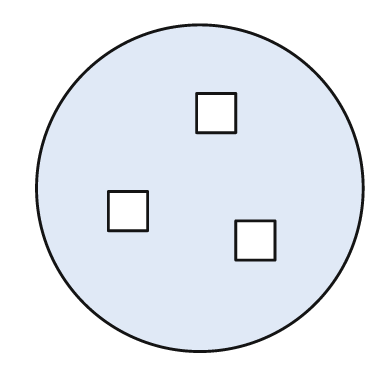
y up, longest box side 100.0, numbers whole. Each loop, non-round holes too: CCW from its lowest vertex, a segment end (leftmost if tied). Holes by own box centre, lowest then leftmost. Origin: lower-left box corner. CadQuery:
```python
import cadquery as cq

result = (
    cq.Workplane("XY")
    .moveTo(50.0, 50.0)
    .circle(50.0)
    .moveTo(61.0, 28.0)
    .lineTo(73.0, 28.0)
    .lineTo(73.0, 40.0)
    .lineTo(61.0, 40.0)
    .close()
    .moveTo(22.0, 37.0)
    .lineTo(34.0, 37.0)
    .lineTo(34.0, 49.0)
    .lineTo(22.0, 49.0)
    .close()
    .moveTo(49.0, 67.0)
    .lineTo(61.0, 67.0)
    .lineTo(61.0, 79.0)
    .lineTo(49.0, 79.0)
    .close()
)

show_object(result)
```